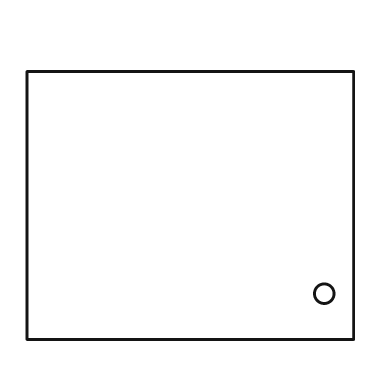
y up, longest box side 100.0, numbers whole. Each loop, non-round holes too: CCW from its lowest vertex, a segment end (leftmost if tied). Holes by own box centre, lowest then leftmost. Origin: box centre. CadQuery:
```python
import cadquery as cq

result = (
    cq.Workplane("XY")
    .moveTo(-50.0, -41.0)
    .lineTo(50.0, -41.0)
    .lineTo(50.0, 41.0)
    .lineTo(-50.0, 41.0)
    .close()
    .moveTo(41.0, -27.0)
    .circle(3.0)
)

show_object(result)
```